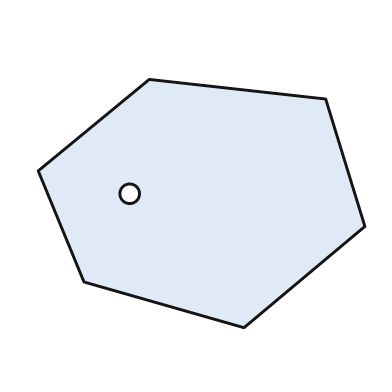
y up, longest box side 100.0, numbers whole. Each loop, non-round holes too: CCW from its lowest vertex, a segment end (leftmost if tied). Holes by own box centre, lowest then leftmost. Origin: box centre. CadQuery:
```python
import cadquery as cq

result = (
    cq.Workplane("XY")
    .moveTo(13.0, -38.0)
    .lineTo(50.0, -7.0)
    .lineTo(38.0, 32.0)
    .lineTo(-16.0, 38.0)
    .lineTo(-50.0, 10.0)
    .lineTo(-36.0, -24.0)
    .close()
    .moveTo(-22.0, 3.0)
    .circle(3.0)
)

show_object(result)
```